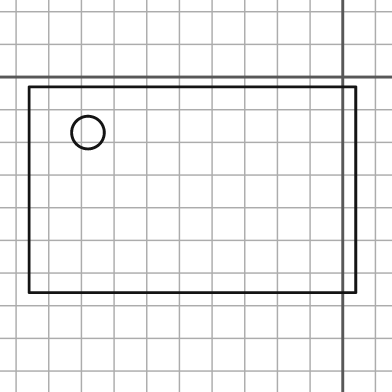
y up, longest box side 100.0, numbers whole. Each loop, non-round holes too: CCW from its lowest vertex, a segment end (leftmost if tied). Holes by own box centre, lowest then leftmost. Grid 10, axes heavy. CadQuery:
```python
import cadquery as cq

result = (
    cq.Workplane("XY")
    .moveTo(-96.0, -66.0)
    .lineTo(4.0, -66.0)
    .lineTo(4.0, -3.0)
    .lineTo(-96.0, -3.0)
    .close()
    .moveTo(-78.0, -17.0)
    .circle(5.0)
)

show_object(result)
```